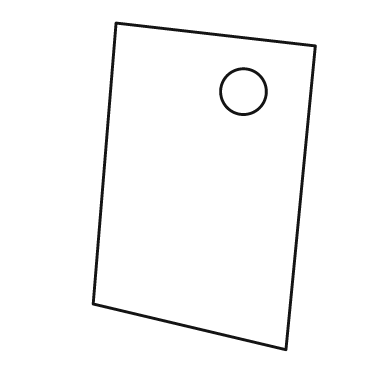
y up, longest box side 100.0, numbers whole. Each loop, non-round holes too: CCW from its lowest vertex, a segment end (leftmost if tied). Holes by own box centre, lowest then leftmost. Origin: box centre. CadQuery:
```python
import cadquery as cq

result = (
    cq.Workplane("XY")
    .moveTo(25.0, -50.0)
    .lineTo(34.0, 43.0)
    .lineTo(-27.0, 50.0)
    .lineTo(-34.0, -36.0)
    .close()
    .moveTo(12.0, 29.0)
    .circle(7.0)
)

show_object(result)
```